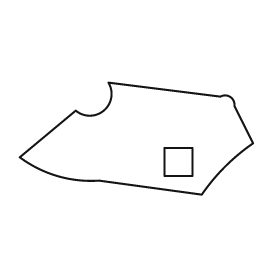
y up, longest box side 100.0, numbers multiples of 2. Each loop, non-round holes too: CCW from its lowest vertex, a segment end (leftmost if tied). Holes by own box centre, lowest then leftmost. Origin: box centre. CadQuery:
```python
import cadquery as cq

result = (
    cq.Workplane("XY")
    .moveTo(28.0, -24.0)
    .threePointArc((38.0, -12.0), (50.0, -2.0))
    .lineTo(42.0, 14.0)
    .threePointArc((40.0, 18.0), (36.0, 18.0))
    .lineTo(-12.0, 24.0)
    .threePointArc((-14.0, 12.0), (-26.0, 12.0))
    .lineTo(-50.0, -8.0)
    .threePointArc((-34.0, -16.0), (-16.0, -18.0))
    .close()
    .moveTo(12.0, -16.0)
    .lineTo(24.0, -16.0)
    .lineTo(24.0, -4.0)
    .lineTo(12.0, -4.0)
    .close()
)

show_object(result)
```